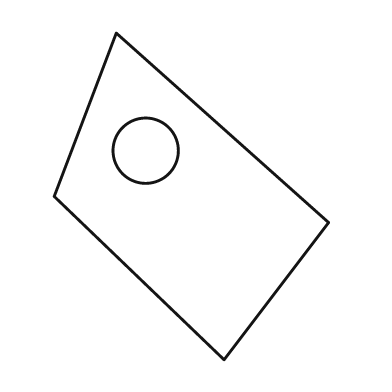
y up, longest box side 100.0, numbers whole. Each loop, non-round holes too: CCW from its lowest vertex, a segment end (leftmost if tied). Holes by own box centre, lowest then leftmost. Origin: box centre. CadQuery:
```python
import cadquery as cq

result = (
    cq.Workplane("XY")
    .moveTo(10.0, -50.0)
    .lineTo(42.0, -8.0)
    .lineTo(-23.0, 50.0)
    .lineTo(-42.0, 0.0)
    .close()
    .moveTo(-14.0, 14.0)
    .circle(10.0)
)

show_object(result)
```